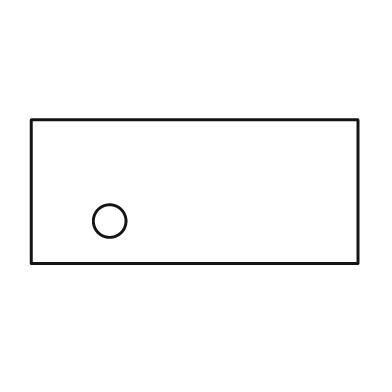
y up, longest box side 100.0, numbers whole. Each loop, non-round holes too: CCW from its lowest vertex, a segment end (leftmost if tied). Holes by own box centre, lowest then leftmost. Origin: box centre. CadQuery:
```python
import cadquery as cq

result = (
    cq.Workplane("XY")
    .moveTo(-50.0, -22.0)
    .lineTo(50.0, -22.0)
    .lineTo(50.0, 22.0)
    .lineTo(-50.0, 22.0)
    .close()
    .moveTo(-26.0, -9.0)
    .circle(5.0)
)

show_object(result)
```